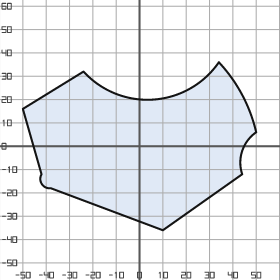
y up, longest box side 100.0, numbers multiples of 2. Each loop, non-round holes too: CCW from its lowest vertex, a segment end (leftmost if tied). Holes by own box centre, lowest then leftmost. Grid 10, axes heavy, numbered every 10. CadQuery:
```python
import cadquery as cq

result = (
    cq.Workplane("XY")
    .moveTo(10.0, -36.0)
    .lineTo(44.0, -12.0)
    .threePointArc((44.0, -2.0), (50.0, 6.0))
    .threePointArc((44.0, 22.0), (34.0, 36.0))
    .threePointArc((6.0, 20.0), (-24.0, 32.0))
    .lineTo(-50.0, 16.0)
    .lineTo(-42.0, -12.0)
    .threePointArc((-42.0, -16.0), (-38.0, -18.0))
    .close()
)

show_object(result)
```